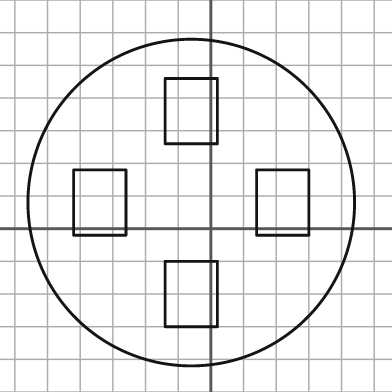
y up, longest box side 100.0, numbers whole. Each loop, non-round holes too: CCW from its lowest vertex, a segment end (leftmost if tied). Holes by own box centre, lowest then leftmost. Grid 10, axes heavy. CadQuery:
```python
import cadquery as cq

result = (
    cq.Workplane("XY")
    .moveTo(-6.0, 8.0)
    .circle(50.0)
    .moveTo(-14.0, -30.0)
    .lineTo(2.0, -30.0)
    .lineTo(2.0, -10.0)
    .lineTo(-14.0, -10.0)
    .close()
    .moveTo(-42.0, -2.0)
    .lineTo(-26.0, -2.0)
    .lineTo(-26.0, 18.0)
    .lineTo(-42.0, 18.0)
    .close()
    .moveTo(14.0, -2.0)
    .lineTo(30.0, -2.0)
    .lineTo(30.0, 18.0)
    .lineTo(14.0, 18.0)
    .close()
    .moveTo(-14.0, 26.0)
    .lineTo(2.0, 26.0)
    .lineTo(2.0, 46.0)
    .lineTo(-14.0, 46.0)
    .close()
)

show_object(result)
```